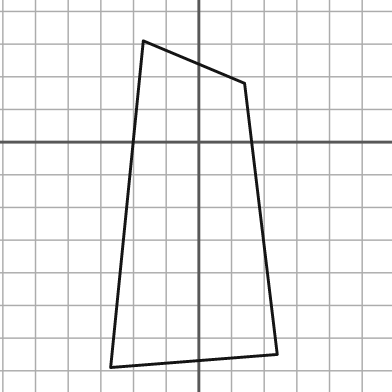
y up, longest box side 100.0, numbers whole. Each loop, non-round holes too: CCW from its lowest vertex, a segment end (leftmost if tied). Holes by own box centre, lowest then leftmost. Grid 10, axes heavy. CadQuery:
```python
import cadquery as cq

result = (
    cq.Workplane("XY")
    .moveTo(-27.0, -69.0)
    .lineTo(24.0, -65.0)
    .lineTo(14.0, 18.0)
    .lineTo(-17.0, 31.0)
    .close()
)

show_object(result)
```